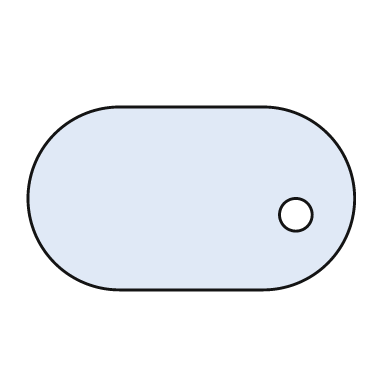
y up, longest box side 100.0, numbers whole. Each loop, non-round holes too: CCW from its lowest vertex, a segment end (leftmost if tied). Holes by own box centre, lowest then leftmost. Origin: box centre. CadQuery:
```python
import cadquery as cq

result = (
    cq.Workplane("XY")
    .moveTo(-22.0, -28.0)
    .lineTo(22.0, -28.0)
    .threePointArc((50.0, 0.0), (22.0, 28.0))
    .lineTo(-22.0, 28.0)
    .threePointArc((-50.0, 0.0), (-22.0, -28.0))
    .close()
    .moveTo(32.0, -5.0)
    .circle(5.0)
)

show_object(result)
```